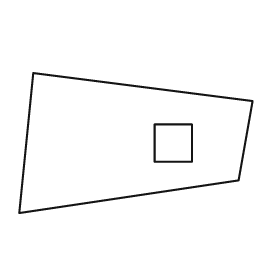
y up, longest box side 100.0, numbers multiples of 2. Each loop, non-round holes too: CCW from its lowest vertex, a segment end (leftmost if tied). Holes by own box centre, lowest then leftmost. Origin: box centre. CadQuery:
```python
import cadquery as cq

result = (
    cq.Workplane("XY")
    .moveTo(-50.0, -30.0)
    .lineTo(44.0, -16.0)
    .lineTo(50.0, 18.0)
    .lineTo(-44.0, 30.0)
    .close()
    .moveTo(8.0, -8.0)
    .lineTo(24.0, -8.0)
    .lineTo(24.0, 8.0)
    .lineTo(8.0, 8.0)
    .close()
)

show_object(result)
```